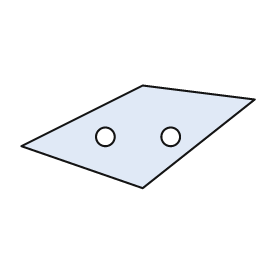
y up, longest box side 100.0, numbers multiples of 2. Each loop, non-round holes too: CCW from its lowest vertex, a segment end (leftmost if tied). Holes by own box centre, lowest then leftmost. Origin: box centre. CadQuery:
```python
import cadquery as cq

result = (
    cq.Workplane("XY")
    .moveTo(2.0, -22.0)
    .lineTo(50.0, 16.0)
    .lineTo(2.0, 22.0)
    .lineTo(-50.0, -4.0)
    .close()
    .moveTo(-14.0, 0.0)
    .circle(4.0)
    .moveTo(14.0, 0.0)
    .circle(4.0)
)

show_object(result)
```